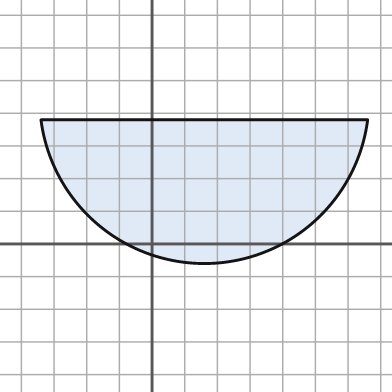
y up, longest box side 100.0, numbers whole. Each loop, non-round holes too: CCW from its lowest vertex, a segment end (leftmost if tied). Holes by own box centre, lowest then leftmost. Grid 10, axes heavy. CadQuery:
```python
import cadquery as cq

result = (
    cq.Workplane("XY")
    .moveTo(-34.0, 38.0)
    .threePointArc((16.0, -6.0), (66.0, 38.0))
    .close()
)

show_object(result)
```